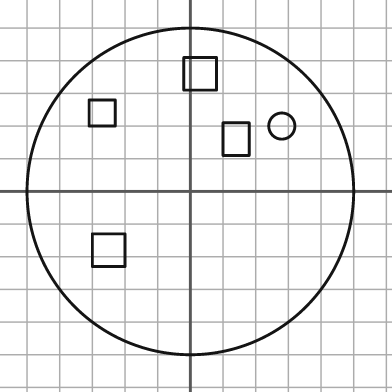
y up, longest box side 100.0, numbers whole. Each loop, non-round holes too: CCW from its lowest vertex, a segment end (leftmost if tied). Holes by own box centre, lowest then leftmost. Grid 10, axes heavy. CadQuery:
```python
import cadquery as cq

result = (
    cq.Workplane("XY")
    .moveTo(0.0, 0.0)
    .circle(50.0)
    .moveTo(-30.0, -23.0)
    .lineTo(-20.0, -23.0)
    .lineTo(-20.0, -13.0)
    .lineTo(-30.0, -13.0)
    .close()
    .moveTo(10.0, 11.0)
    .lineTo(18.0, 11.0)
    .lineTo(18.0, 21.0)
    .lineTo(10.0, 21.0)
    .close()
    .moveTo(28.0, 20.0)
    .circle(4.0)
    .moveTo(-31.0, 20.0)
    .lineTo(-23.0, 20.0)
    .lineTo(-23.0, 28.0)
    .lineTo(-31.0, 28.0)
    .close()
    .moveTo(-2.0, 31.0)
    .lineTo(8.0, 31.0)
    .lineTo(8.0, 41.0)
    .lineTo(-2.0, 41.0)
    .close()
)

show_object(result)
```